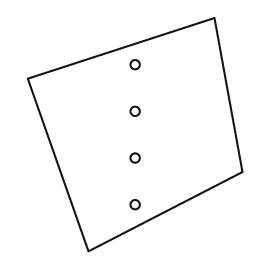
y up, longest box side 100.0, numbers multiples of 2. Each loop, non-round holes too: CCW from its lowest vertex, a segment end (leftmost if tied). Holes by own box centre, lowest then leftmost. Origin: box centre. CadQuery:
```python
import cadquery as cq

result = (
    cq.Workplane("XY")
    .moveTo(-20.0, -50.0)
    .lineTo(46.0, -16.0)
    .lineTo(34.0, 50.0)
    .lineTo(-46.0, 24.0)
    .close()
    .moveTo(0.0, -30.0)
    .circle(2.0)
    .moveTo(0.0, -10.0)
    .circle(2.0)
    .moveTo(0.0, 10.0)
    .circle(2.0)
    .moveTo(0.0, 30.0)
    .circle(2.0)
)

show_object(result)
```